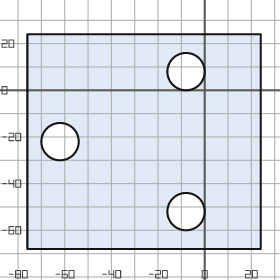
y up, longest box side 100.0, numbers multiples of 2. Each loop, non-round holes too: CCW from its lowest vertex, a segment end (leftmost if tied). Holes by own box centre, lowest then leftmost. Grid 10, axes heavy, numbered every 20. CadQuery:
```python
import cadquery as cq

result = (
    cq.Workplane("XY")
    .moveTo(-76.0, -68.0)
    .lineTo(24.0, -68.0)
    .lineTo(24.0, 24.0)
    .lineTo(-76.0, 24.0)
    .close()
    .moveTo(-8.0, -52.0)
    .circle(8.0)
    .moveTo(-62.0, -22.0)
    .circle(8.0)
    .moveTo(-8.0, 8.0)
    .circle(8.0)
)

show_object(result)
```